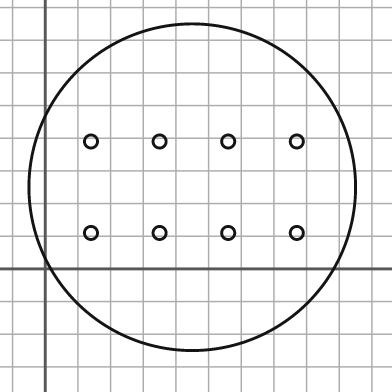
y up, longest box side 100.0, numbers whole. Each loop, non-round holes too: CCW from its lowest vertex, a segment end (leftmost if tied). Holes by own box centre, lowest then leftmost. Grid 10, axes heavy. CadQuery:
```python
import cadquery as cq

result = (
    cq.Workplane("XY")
    .moveTo(45.0, 25.0)
    .circle(50.0)
    .moveTo(14.0, 11.0)
    .circle(2.0)
    .moveTo(35.0, 11.0)
    .circle(2.0)
    .moveTo(56.0, 11.0)
    .circle(2.0)
    .moveTo(77.0, 11.0)
    .circle(2.0)
    .moveTo(14.0, 39.0)
    .circle(2.0)
    .moveTo(35.0, 39.0)
    .circle(2.0)
    .moveTo(56.0, 39.0)
    .circle(2.0)
    .moveTo(77.0, 39.0)
    .circle(2.0)
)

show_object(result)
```